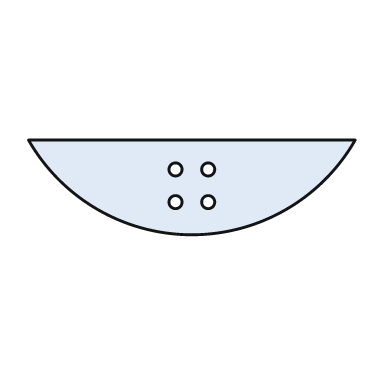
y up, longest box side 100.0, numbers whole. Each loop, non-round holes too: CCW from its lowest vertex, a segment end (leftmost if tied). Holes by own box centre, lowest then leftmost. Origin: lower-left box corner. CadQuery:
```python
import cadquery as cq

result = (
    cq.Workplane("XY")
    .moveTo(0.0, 29.0)
    .threePointArc((50.0, 0.0), (100.0, 29.0))
    .close()
    .moveTo(45.0, 10.0)
    .circle(2.0)
    .moveTo(55.0, 10.0)
    .circle(2.0)
    .moveTo(45.0, 20.0)
    .circle(2.0)
    .moveTo(55.0, 20.0)
    .circle(2.0)
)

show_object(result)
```